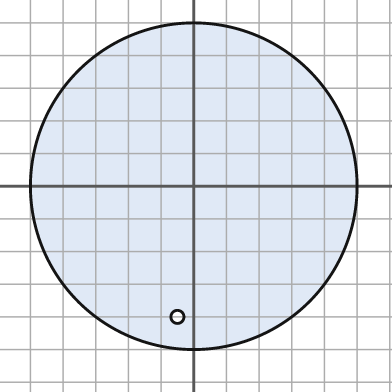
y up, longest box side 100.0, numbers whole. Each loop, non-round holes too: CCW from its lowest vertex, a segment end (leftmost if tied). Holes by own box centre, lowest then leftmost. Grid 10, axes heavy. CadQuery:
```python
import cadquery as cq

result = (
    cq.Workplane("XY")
    .moveTo(0.0, 0.0)
    .circle(50.0)
    .moveTo(-5.0, -40.0)
    .circle(2.0)
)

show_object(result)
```